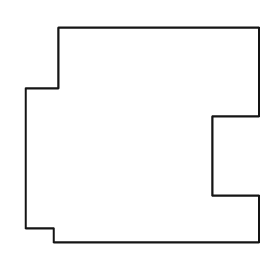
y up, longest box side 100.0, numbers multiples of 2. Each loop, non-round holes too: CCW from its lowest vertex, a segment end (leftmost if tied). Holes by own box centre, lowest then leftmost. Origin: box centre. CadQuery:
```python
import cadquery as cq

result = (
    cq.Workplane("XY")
    .moveTo(-38.0, -46.0)
    .lineTo(50.0, -46.0)
    .lineTo(50.0, -26.0)
    .lineTo(30.0, -26.0)
    .lineTo(30.0, 8.0)
    .lineTo(50.0, 8.0)
    .lineTo(50.0, 46.0)
    .lineTo(-36.0, 46.0)
    .lineTo(-36.0, 20.0)
    .lineTo(-50.0, 20.0)
    .lineTo(-50.0, -40.0)
    .lineTo(-38.0, -40.0)
    .close()
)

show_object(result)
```